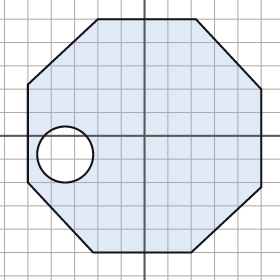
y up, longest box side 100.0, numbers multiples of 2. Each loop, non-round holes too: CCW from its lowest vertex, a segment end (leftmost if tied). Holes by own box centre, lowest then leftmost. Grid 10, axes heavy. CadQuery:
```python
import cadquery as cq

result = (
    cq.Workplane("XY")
    .moveTo(-22.0, -50.0)
    .lineTo(20.0, -50.0)
    .lineTo(50.0, -22.0)
    .lineTo(50.0, 20.0)
    .lineTo(22.0, 50.0)
    .lineTo(-20.0, 50.0)
    .lineTo(-50.0, 22.0)
    .lineTo(-50.0, -20.0)
    .close()
    .moveTo(-34.0, -8.0)
    .circle(12.0)
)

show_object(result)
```